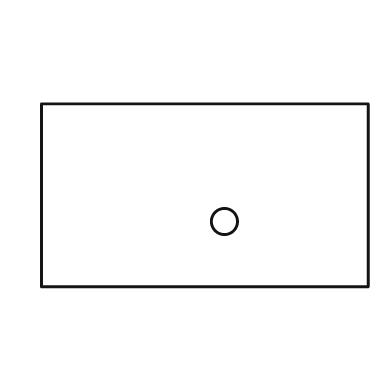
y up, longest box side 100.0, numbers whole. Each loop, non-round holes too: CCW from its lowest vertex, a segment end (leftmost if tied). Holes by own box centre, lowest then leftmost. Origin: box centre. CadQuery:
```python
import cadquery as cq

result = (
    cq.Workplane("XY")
    .moveTo(-50.0, -28.0)
    .lineTo(50.0, -28.0)
    .lineTo(50.0, 28.0)
    .lineTo(-50.0, 28.0)
    .close()
    .moveTo(6.0, -8.0)
    .circle(4.0)
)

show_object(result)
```